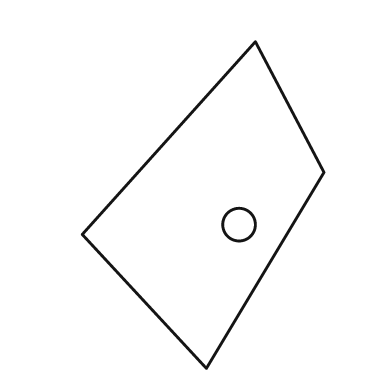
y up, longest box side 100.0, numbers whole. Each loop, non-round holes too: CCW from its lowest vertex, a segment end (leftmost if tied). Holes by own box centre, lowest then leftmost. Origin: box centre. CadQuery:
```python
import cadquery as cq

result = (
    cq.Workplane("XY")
    .moveTo(1.0, -50.0)
    .lineTo(37.0, 10.0)
    .lineTo(16.0, 50.0)
    .lineTo(-37.0, -9.0)
    .close()
    .moveTo(11.0, -6.0)
    .circle(5.0)
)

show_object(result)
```